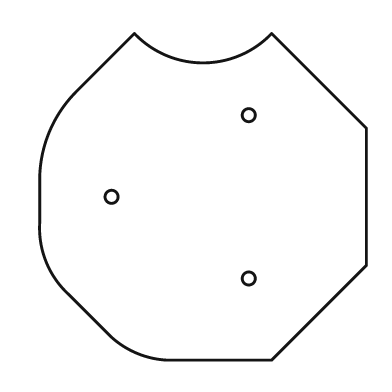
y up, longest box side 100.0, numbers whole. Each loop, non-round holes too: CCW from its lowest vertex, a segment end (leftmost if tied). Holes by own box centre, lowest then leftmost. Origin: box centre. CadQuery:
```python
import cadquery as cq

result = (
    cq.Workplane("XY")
    .moveTo(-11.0, -50.0)
    .lineTo(21.0, -50.0)
    .lineTo(50.0, -21.0)
    .lineTo(50.0, 21.0)
    .lineTo(21.0, 50.0)
    .threePointArc((0.0, 41.0), (-21.0, 50.0))
    .lineTo(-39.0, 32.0)
    .threePointArc((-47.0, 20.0), (-50.0, 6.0))
    .lineTo(-50.0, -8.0)
    .threePointArc((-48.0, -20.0), (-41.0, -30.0))
    .lineTo(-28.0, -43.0)
    .threePointArc((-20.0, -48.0), (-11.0, -50.0))
    .close()
    .moveTo(14.0, -25.0)
    .circle(2.0)
    .moveTo(-28.0, 0.0)
    .circle(2.0)
    .moveTo(14.0, 25.0)
    .circle(2.0)
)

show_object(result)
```